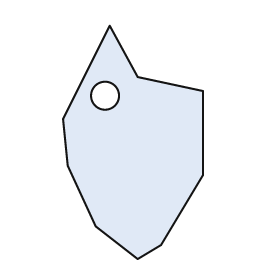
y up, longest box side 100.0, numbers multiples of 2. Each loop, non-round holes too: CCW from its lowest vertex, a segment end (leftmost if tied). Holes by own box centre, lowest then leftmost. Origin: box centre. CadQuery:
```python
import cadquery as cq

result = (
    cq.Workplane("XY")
    .moveTo(2.0, -50.0)
    .lineTo(12.0, -44.0)
    .lineTo(30.0, -14.0)
    .lineTo(30.0, 22.0)
    .lineTo(2.0, 28.0)
    .lineTo(-10.0, 50.0)
    .lineTo(-30.0, 10.0)
    .lineTo(-28.0, -10.0)
    .lineTo(-16.0, -36.0)
    .close()
    .moveTo(-12.0, 20.0)
    .circle(6.0)
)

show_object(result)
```